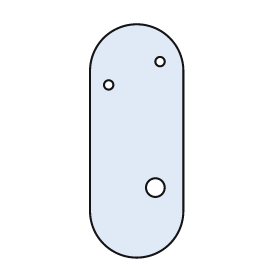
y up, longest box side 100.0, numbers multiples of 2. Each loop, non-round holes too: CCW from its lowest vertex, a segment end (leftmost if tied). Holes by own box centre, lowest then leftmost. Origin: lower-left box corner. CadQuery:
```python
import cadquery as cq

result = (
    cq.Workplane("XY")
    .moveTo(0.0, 20.0)
    .threePointArc((20.0, 0.0), (40.0, 20.0))
    .lineTo(40.0, 80.0)
    .threePointArc((20.0, 100.0), (0.0, 80.0))
    .close()
    .moveTo(28.0, 30.0)
    .circle(4.0)
    .moveTo(8.0, 74.0)
    .circle(2.0)
    .moveTo(30.0, 84.0)
    .circle(2.0)
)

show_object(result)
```